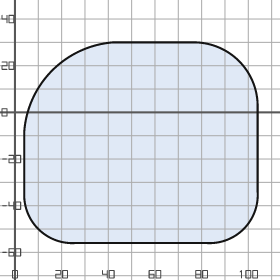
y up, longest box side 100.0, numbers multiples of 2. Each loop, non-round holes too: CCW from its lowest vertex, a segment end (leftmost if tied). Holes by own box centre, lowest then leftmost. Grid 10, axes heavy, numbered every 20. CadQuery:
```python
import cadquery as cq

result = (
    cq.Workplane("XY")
    .moveTo(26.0, -56.0)
    .lineTo(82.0, -56.0)
    .threePointArc((98.0, -50.0), (104.0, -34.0))
    .lineTo(104.0, 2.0)
    .threePointArc((96.0, 22.0), (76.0, 30.0))
    .lineTo(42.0, 30.0)
    .threePointArc((16.0, 18.0), (4.0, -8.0))
    .lineTo(4.0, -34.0)
    .threePointArc((10.0, -50.0), (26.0, -56.0))
    .close()
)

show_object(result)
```